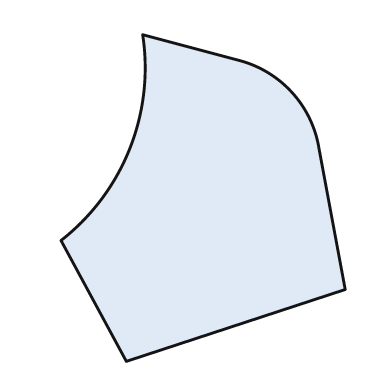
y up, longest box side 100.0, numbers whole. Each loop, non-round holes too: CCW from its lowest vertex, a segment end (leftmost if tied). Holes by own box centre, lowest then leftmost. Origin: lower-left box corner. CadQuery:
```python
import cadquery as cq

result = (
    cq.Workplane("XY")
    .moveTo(20.0, 0.0)
    .lineTo(87.0, 22.0)
    .lineTo(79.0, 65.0)
    .threePointArc((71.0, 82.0), (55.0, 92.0))
    .lineTo(25.0, 100.0)
    .threePointArc((21.0, 65.0), (0.0, 37.0))
    .close()
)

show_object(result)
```